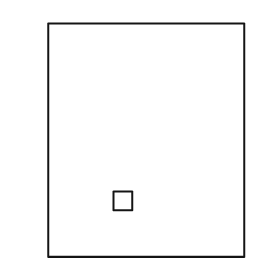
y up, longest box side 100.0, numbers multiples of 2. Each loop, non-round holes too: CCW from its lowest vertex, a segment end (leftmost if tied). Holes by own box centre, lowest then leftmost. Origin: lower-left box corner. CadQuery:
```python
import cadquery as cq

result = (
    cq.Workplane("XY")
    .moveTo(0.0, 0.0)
    .lineTo(84.0, 0.0)
    .lineTo(84.0, 100.0)
    .lineTo(0.0, 100.0)
    .close()
    .moveTo(28.0, 20.0)
    .lineTo(36.0, 20.0)
    .lineTo(36.0, 28.0)
    .lineTo(28.0, 28.0)
    .close()
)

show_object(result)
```